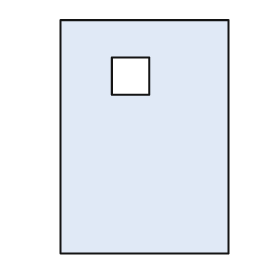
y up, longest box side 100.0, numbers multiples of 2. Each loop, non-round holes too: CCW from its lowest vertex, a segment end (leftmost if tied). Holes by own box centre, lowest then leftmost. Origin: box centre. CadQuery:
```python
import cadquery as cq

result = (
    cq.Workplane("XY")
    .moveTo(-36.0, -50.0)
    .lineTo(36.0, -50.0)
    .lineTo(36.0, 50.0)
    .lineTo(-36.0, 50.0)
    .close()
    .moveTo(-14.0, 18.0)
    .lineTo(2.0, 18.0)
    .lineTo(2.0, 34.0)
    .lineTo(-14.0, 34.0)
    .close()
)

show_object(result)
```